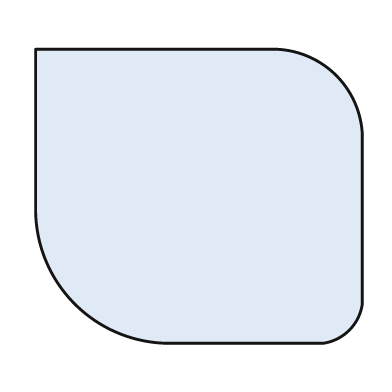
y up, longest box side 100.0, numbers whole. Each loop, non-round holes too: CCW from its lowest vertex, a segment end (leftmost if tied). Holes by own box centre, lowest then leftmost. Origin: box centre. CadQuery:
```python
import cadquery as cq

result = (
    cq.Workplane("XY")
    .moveTo(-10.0, -45.0)
    .lineTo(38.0, -45.0)
    .threePointArc((46.0, -41.0), (50.0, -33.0))
    .lineTo(50.0, 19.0)
    .threePointArc((42.0, 37.0), (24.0, 45.0))
    .lineTo(-50.0, 45.0)
    .lineTo(-50.0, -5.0)
    .threePointArc((-38.0, -33.0), (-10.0, -45.0))
    .close()
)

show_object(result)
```